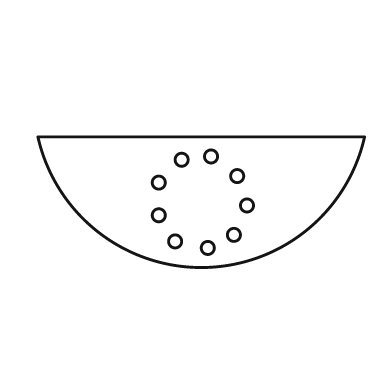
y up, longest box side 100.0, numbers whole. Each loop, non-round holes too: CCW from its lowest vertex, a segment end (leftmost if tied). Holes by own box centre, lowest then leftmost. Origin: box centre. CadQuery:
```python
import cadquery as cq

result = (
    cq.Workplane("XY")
    .moveTo(-50.0, 20.0)
    .threePointArc((0.0, -20.0), (50.0, 20.0))
    .close()
    .moveTo(2.0, -14.0)
    .circle(2.0)
    .moveTo(-8.0, -12.0)
    .circle(2.0)
    .moveTo(10.0, -10.0)
    .circle(2.0)
    .moveTo(-13.0, -4.0)
    .circle(2.0)
    .moveTo(14.0, -1.0)
    .circle(2.0)
    .moveTo(-13.0, 6.0)
    .circle(2.0)
    .moveTo(11.0, 8.0)
    .circle(2.0)
    .moveTo(-6.0, 13.0)
    .circle(2.0)
    .moveTo(3.0, 14.0)
    .circle(2.0)
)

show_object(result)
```